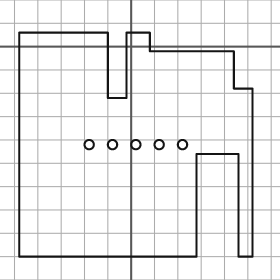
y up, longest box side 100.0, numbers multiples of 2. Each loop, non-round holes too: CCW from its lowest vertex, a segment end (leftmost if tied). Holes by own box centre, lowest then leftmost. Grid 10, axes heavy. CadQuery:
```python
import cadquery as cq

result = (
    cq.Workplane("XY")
    .moveTo(-48.0, -90.0)
    .lineTo(28.0, -90.0)
    .lineTo(28.0, -46.0)
    .lineTo(46.0, -46.0)
    .lineTo(46.0, -90.0)
    .lineTo(52.0, -90.0)
    .lineTo(52.0, -18.0)
    .lineTo(44.0, -18.0)
    .lineTo(44.0, -2.0)
    .lineTo(8.0, -2.0)
    .lineTo(8.0, 6.0)
    .lineTo(-2.0, 6.0)
    .lineTo(-2.0, -22.0)
    .lineTo(-10.0, -22.0)
    .lineTo(-10.0, 6.0)
    .lineTo(-48.0, 6.0)
    .close()
    .moveTo(-18.0, -42.0)
    .circle(2.0)
    .moveTo(-8.0, -42.0)
    .circle(2.0)
    .moveTo(2.0, -42.0)
    .circle(2.0)
    .moveTo(12.0, -42.0)
    .circle(2.0)
    .moveTo(22.0, -42.0)
    .circle(2.0)
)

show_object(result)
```